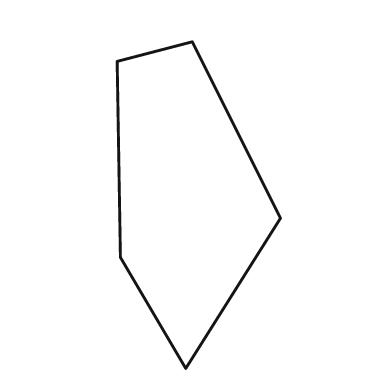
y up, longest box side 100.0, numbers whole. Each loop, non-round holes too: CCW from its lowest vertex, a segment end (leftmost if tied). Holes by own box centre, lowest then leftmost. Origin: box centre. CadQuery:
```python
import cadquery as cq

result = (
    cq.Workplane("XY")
    .moveTo(-4.0, -50.0)
    .lineTo(25.0, -4.0)
    .lineTo(-2.0, 50.0)
    .lineTo(-25.0, 44.0)
    .lineTo(-24.0, -16.0)
    .close()
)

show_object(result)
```